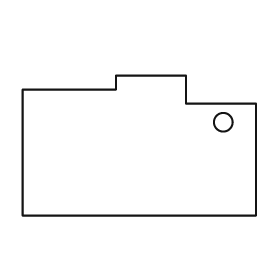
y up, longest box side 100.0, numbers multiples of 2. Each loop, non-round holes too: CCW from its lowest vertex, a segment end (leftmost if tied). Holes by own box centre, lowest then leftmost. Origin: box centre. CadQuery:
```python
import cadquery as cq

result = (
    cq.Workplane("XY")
    .moveTo(-50.0, -30.0)
    .lineTo(50.0, -30.0)
    .lineTo(50.0, 18.0)
    .lineTo(20.0, 18.0)
    .lineTo(20.0, 30.0)
    .lineTo(-10.0, 30.0)
    .lineTo(-10.0, 24.0)
    .lineTo(-50.0, 24.0)
    .close()
    .moveTo(36.0, 10.0)
    .circle(4.0)
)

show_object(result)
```